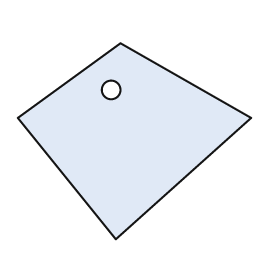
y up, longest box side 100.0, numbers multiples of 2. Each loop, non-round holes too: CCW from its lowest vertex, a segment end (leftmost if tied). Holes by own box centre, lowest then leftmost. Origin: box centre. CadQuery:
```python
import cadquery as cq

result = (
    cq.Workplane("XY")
    .moveTo(-8.0, -42.0)
    .lineTo(50.0, 10.0)
    .lineTo(-6.0, 42.0)
    .lineTo(-50.0, 10.0)
    .close()
    .moveTo(-10.0, 22.0)
    .circle(4.0)
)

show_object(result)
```